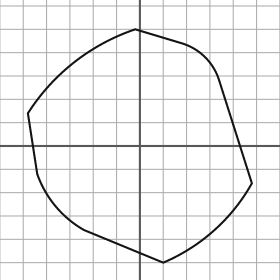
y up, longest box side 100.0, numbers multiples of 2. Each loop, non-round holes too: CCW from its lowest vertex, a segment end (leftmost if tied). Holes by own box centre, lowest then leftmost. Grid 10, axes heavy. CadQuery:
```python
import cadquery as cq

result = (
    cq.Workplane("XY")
    .moveTo(10.0, -50.0)
    .threePointArc((32.0, -36.0), (48.0, -16.0))
    .lineTo(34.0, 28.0)
    .threePointArc((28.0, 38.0), (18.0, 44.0))
    .lineTo(-2.0, 50.0)
    .threePointArc((-28.0, 36.0), (-48.0, 14.0))
    .lineTo(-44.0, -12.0)
    .threePointArc((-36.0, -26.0), (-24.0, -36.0))
    .close()
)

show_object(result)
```